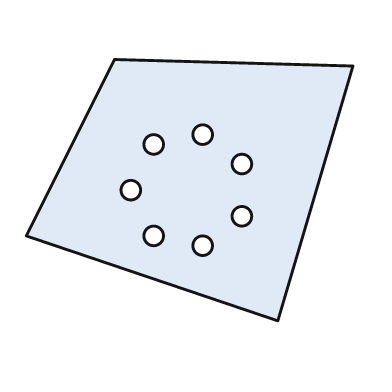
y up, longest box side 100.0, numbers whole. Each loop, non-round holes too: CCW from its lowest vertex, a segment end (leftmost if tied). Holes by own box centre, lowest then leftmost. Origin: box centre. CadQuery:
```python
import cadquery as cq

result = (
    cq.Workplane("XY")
    .moveTo(27.0, -40.0)
    .lineTo(50.0, 38.0)
    .lineTo(-23.0, 40.0)
    .lineTo(-50.0, -14.0)
    .close()
    .moveTo(4.0, -17.0)
    .circle(3.0)
    .moveTo(-11.0, -14.0)
    .circle(3.0)
    .moveTo(16.0, -8.0)
    .circle(3.0)
    .moveTo(-18.0, 0.0)
    .circle(3.0)
    .moveTo(16.0, 8.0)
    .circle(3.0)
    .moveTo(-11.0, 14.0)
    .circle(3.0)
    .moveTo(4.0, 17.0)
    .circle(3.0)
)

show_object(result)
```